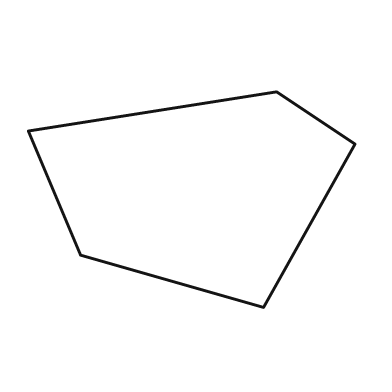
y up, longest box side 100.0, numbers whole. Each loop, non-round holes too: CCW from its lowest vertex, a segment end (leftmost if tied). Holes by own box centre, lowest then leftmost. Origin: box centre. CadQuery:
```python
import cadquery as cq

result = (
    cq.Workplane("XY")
    .moveTo(22.0, -33.0)
    .lineTo(50.0, 17.0)
    .lineTo(26.0, 33.0)
    .lineTo(-50.0, 21.0)
    .lineTo(-34.0, -17.0)
    .close()
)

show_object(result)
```